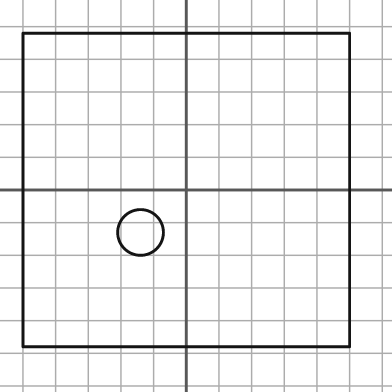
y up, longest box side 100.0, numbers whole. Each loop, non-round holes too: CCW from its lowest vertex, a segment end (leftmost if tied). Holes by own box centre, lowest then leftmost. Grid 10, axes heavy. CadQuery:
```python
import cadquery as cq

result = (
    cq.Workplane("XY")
    .moveTo(-50.0, -48.0)
    .lineTo(50.0, -48.0)
    .lineTo(50.0, 48.0)
    .lineTo(-50.0, 48.0)
    .close()
    .moveTo(-14.0, -13.0)
    .circle(7.0)
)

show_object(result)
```